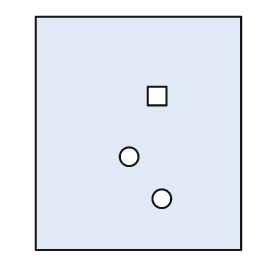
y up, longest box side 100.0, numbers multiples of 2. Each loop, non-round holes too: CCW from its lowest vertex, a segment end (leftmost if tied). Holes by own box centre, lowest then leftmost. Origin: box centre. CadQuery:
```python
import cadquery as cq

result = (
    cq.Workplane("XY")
    .moveTo(-44.0, -50.0)
    .lineTo(44.0, -50.0)
    .lineTo(44.0, 50.0)
    .lineTo(-44.0, 50.0)
    .close()
    .moveTo(10.0, -28.0)
    .circle(4.0)
    .moveTo(-4.0, -10.0)
    .circle(4.0)
    .moveTo(4.0, 12.0)
    .lineTo(12.0, 12.0)
    .lineTo(12.0, 20.0)
    .lineTo(4.0, 20.0)
    .close()
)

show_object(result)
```